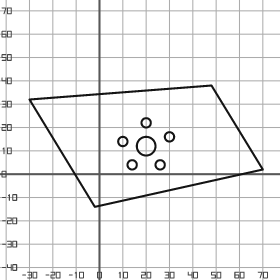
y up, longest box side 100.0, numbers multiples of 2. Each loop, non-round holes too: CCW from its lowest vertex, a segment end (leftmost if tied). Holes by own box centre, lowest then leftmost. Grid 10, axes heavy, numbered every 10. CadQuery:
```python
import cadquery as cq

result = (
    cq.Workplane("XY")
    .moveTo(-2.0, -14.0)
    .lineTo(70.0, 2.0)
    .lineTo(48.0, 38.0)
    .lineTo(-30.0, 32.0)
    .close()
    .moveTo(14.0, 4.0)
    .circle(2.0)
    .moveTo(26.0, 4.0)
    .circle(2.0)
    .moveTo(20.0, 12.0)
    .circle(4.0)
    .moveTo(10.0, 14.0)
    .circle(2.0)
    .moveTo(30.0, 16.0)
    .circle(2.0)
    .moveTo(20.0, 22.0)
    .circle(2.0)
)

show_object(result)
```